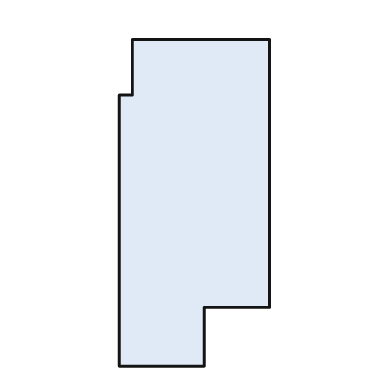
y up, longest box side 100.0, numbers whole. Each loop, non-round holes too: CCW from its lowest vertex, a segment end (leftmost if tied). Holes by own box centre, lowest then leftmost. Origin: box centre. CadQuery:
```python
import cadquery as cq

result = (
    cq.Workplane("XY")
    .moveTo(-23.0, -50.0)
    .lineTo(3.0, -50.0)
    .lineTo(3.0, -32.0)
    .lineTo(23.0, -32.0)
    .lineTo(23.0, 50.0)
    .lineTo(-19.0, 50.0)
    .lineTo(-19.0, 33.0)
    .lineTo(-23.0, 33.0)
    .close()
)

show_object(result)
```